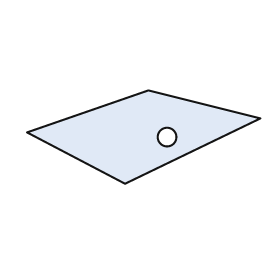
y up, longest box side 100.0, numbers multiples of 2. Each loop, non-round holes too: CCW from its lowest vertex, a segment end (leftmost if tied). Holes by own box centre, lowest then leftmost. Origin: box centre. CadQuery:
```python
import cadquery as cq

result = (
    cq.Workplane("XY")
    .moveTo(-8.0, -20.0)
    .lineTo(50.0, 8.0)
    .lineTo(2.0, 20.0)
    .lineTo(-50.0, 2.0)
    .close()
    .moveTo(10.0, 0.0)
    .circle(4.0)
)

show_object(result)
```